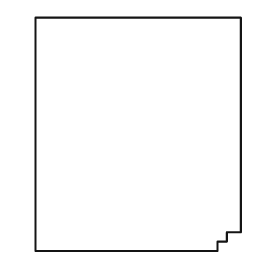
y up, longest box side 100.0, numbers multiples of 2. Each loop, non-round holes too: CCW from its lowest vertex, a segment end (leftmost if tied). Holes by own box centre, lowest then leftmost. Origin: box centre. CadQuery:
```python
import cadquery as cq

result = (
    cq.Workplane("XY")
    .moveTo(-44.0, -50.0)
    .lineTo(34.0, -50.0)
    .lineTo(34.0, -46.0)
    .lineTo(38.0, -46.0)
    .lineTo(38.0, -42.0)
    .lineTo(44.0, -42.0)
    .lineTo(44.0, 50.0)
    .lineTo(-44.0, 50.0)
    .close()
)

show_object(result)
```